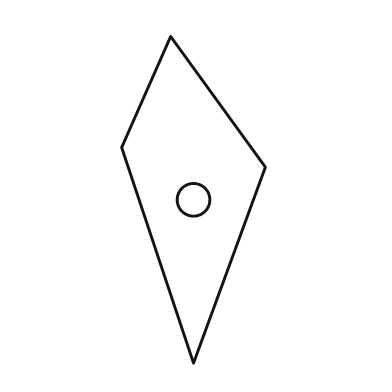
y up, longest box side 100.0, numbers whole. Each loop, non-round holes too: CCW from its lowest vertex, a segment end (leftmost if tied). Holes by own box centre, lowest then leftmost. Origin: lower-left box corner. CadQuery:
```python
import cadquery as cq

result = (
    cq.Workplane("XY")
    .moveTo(22.0, 0.0)
    .lineTo(44.0, 60.0)
    .lineTo(15.0, 100.0)
    .lineTo(0.0, 66.0)
    .close()
    .moveTo(22.0, 50.0)
    .circle(5.0)
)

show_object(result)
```